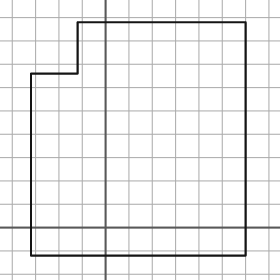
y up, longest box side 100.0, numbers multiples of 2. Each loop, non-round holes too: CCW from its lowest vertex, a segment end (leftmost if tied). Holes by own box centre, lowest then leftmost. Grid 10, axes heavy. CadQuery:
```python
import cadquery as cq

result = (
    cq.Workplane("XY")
    .moveTo(-32.0, -12.0)
    .lineTo(60.0, -12.0)
    .lineTo(60.0, 88.0)
    .lineTo(-12.0, 88.0)
    .lineTo(-12.0, 66.0)
    .lineTo(-32.0, 66.0)
    .close()
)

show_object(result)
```